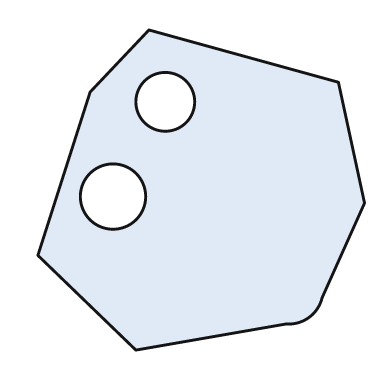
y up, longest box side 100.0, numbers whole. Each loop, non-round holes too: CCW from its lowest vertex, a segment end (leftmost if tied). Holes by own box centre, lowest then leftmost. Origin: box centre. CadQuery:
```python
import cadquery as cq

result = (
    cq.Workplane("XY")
    .moveTo(-20.0, -49.0)
    .lineTo(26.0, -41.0)
    .threePointArc((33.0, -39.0), (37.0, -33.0))
    .lineTo(50.0, -4.0)
    .lineTo(42.0, 33.0)
    .lineTo(-16.0, 49.0)
    .lineTo(-34.0, 30.0)
    .lineTo(-50.0, -20.0)
    .close()
    .moveTo(-27.0, -2.0)
    .circle(10.0)
    .moveTo(-11.0, 27.0)
    .circle(9.0)
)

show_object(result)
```